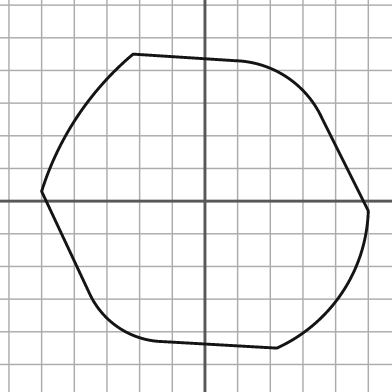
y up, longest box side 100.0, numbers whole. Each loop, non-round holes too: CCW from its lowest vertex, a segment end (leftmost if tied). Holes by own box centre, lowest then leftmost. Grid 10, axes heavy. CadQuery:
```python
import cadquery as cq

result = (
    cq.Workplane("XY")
    .moveTo(22.0, -45.0)
    .threePointArc((42.0, -28.0), (50.0, -3.0))
    .lineTo(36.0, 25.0)
    .threePointArc((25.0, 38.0), (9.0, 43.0))
    .lineTo(-22.0, 45.0)
    .threePointArc((-39.0, 26.0), (-50.0, 3.0))
    .lineTo(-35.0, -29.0)
    .threePointArc((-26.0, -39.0), (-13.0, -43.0))
    .close()
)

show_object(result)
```